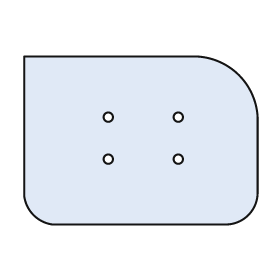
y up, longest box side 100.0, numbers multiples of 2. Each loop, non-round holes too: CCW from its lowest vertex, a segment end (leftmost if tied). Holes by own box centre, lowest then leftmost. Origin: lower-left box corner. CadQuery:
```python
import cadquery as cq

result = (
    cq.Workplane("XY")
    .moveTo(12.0, 0.0)
    .lineTo(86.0, 0.0)
    .threePointArc((96.0, 4.0), (100.0, 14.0))
    .lineTo(100.0, 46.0)
    .threePointArc((92.0, 64.0), (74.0, 72.0))
    .lineTo(0.0, 72.0)
    .lineTo(0.0, 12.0)
    .threePointArc((4.0, 4.0), (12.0, 0.0))
    .close()
    .moveTo(36.0, 28.0)
    .circle(2.0)
    .moveTo(66.0, 28.0)
    .circle(2.0)
    .moveTo(36.0, 46.0)
    .circle(2.0)
    .moveTo(66.0, 46.0)
    .circle(2.0)
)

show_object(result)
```